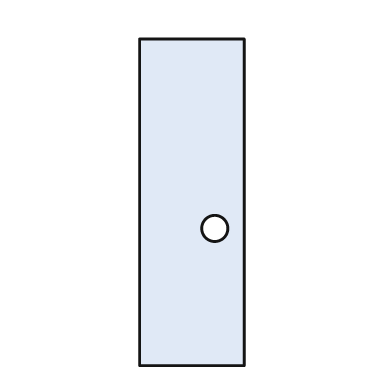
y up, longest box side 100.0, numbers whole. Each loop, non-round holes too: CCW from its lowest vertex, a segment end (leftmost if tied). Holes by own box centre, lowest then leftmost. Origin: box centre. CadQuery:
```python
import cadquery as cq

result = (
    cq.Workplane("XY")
    .moveTo(-16.0, -50.0)
    .lineTo(16.0, -50.0)
    .lineTo(16.0, 50.0)
    .lineTo(-16.0, 50.0)
    .close()
    .moveTo(7.0, -8.0)
    .circle(4.0)
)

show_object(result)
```